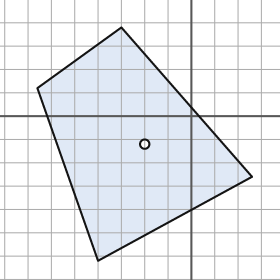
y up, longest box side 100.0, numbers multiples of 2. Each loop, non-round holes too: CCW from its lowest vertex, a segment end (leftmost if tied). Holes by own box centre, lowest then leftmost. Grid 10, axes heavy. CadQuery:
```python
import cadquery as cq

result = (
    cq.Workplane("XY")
    .moveTo(-40.0, -62.0)
    .lineTo(26.0, -26.0)
    .lineTo(-30.0, 38.0)
    .lineTo(-66.0, 12.0)
    .close()
    .moveTo(-20.0, -12.0)
    .circle(2.0)
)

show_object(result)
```